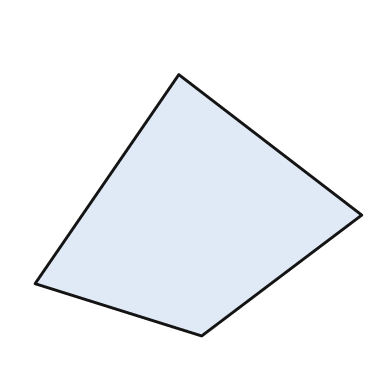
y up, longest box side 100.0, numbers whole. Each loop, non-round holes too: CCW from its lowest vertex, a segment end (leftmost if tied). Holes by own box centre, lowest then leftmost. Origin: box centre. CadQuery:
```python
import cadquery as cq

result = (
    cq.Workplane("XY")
    .moveTo(1.0, -40.0)
    .lineTo(50.0, -3.0)
    .lineTo(-6.0, 40.0)
    .lineTo(-50.0, -24.0)
    .close()
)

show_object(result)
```